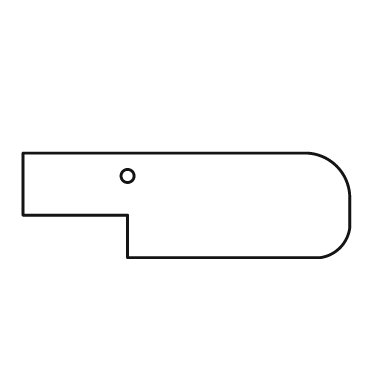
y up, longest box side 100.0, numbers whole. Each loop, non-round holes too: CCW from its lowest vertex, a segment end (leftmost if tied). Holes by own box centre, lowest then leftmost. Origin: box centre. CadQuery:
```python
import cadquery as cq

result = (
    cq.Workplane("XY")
    .moveTo(-18.0, -16.0)
    .lineTo(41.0, -16.0)
    .threePointArc((47.0, -13.0), (50.0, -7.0))
    .lineTo(50.0, 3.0)
    .threePointArc((46.0, 12.0), (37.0, 16.0))
    .lineTo(-50.0, 16.0)
    .lineTo(-50.0, -3.0)
    .lineTo(-18.0, -3.0)
    .close()
    .moveTo(-18.0, 9.0)
    .circle(2.0)
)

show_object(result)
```